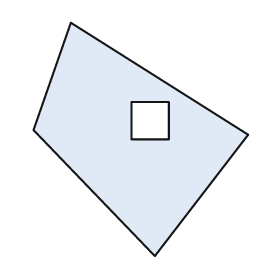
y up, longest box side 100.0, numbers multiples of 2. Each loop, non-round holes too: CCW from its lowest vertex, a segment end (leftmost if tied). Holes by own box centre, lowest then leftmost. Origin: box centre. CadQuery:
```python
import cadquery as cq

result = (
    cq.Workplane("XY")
    .moveTo(6.0, -50.0)
    .lineTo(46.0, 2.0)
    .lineTo(-30.0, 50.0)
    .lineTo(-46.0, 4.0)
    .close()
    .moveTo(-4.0, 0.0)
    .lineTo(12.0, 0.0)
    .lineTo(12.0, 16.0)
    .lineTo(-4.0, 16.0)
    .close()
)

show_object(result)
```